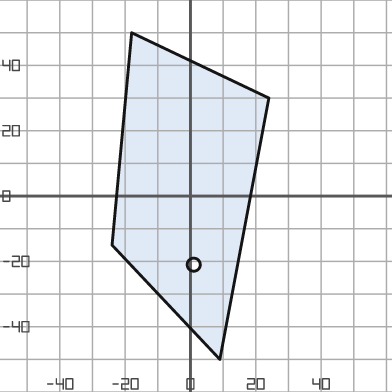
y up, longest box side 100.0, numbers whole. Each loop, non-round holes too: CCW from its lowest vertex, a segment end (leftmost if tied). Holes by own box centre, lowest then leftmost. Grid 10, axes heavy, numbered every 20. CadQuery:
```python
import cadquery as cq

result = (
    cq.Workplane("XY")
    .moveTo(9.0, -50.0)
    .lineTo(24.0, 30.0)
    .lineTo(-18.0, 50.0)
    .lineTo(-24.0, -15.0)
    .close()
    .moveTo(1.0, -21.0)
    .circle(2.0)
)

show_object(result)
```